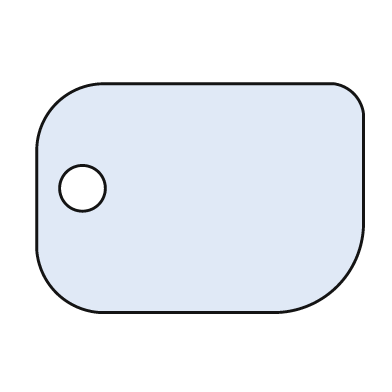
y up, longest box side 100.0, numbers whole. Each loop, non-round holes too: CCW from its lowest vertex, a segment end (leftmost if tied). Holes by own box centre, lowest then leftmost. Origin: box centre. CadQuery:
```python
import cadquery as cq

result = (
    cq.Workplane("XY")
    .moveTo(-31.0, -35.0)
    .lineTo(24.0, -35.0)
    .threePointArc((42.0, -27.0), (50.0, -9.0))
    .lineTo(50.0, 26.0)
    .threePointArc((47.0, 32.0), (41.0, 35.0))
    .lineTo(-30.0, 35.0)
    .threePointArc((-44.0, 29.0), (-50.0, 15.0))
    .lineTo(-50.0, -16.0)
    .threePointArc((-44.0, -29.0), (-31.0, -35.0))
    .close()
    .moveTo(-36.0, 3.0)
    .circle(7.0)
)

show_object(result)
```